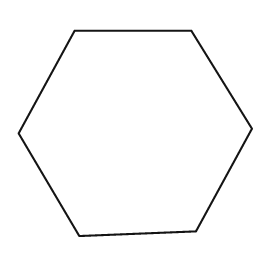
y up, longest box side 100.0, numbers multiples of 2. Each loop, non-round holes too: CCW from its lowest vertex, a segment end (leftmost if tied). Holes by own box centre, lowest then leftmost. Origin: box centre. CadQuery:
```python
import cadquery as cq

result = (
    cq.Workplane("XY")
    .moveTo(-24.0, -44.0)
    .lineTo(26.0, -42.0)
    .lineTo(50.0, 2.0)
    .lineTo(24.0, 44.0)
    .lineTo(-26.0, 44.0)
    .lineTo(-50.0, 0.0)
    .close()
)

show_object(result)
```